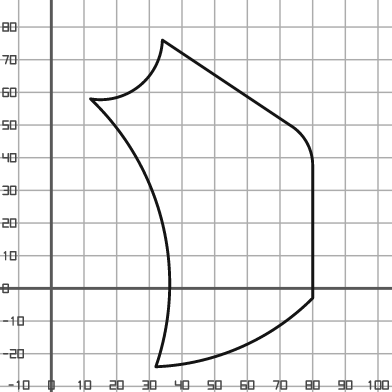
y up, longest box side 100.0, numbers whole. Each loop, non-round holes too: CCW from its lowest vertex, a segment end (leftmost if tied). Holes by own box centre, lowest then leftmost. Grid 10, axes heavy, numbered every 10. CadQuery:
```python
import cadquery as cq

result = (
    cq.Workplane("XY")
    .moveTo(32.0, -24.0)
    .threePointArc((58.0, -18.0), (80.0, -3.0))
    .lineTo(80.0, 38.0)
    .threePointArc((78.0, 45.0), (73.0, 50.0))
    .lineTo(34.0, 76.0)
    .threePointArc((27.0, 62.0), (12.0, 58.0))
    .threePointArc((34.0, 20.0), (32.0, -24.0))
    .close()
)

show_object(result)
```